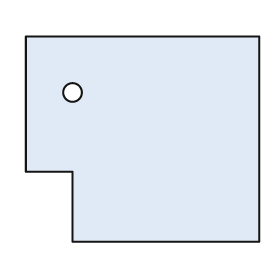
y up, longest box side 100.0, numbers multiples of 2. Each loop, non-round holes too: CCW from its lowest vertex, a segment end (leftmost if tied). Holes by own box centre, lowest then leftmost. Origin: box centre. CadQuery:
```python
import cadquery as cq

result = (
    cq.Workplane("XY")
    .moveTo(-30.0, -44.0)
    .lineTo(50.0, -44.0)
    .lineTo(50.0, 44.0)
    .lineTo(-50.0, 44.0)
    .lineTo(-50.0, -14.0)
    .lineTo(-30.0, -14.0)
    .close()
    .moveTo(-30.0, 20.0)
    .circle(4.0)
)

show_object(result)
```